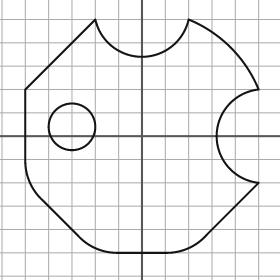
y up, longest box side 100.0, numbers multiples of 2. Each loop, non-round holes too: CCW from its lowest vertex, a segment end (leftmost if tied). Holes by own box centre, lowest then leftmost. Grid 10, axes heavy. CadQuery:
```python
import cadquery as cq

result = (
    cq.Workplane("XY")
    .moveTo(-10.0, -50.0)
    .lineTo(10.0, -50.0)
    .threePointArc((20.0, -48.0), (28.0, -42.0))
    .lineTo(50.0, -20.0)
    .threePointArc((32.0, 0.0), (50.0, 20.0))
    .threePointArc((38.0, 38.0), (20.0, 50.0))
    .threePointArc((0.0, 34.0), (-20.0, 50.0))
    .lineTo(-50.0, 20.0)
    .lineTo(-50.0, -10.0)
    .threePointArc((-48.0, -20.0), (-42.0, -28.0))
    .lineTo(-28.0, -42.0)
    .threePointArc((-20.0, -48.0), (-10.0, -50.0))
    .close()
    .moveTo(-30.0, 4.0)
    .circle(10.0)
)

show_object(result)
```